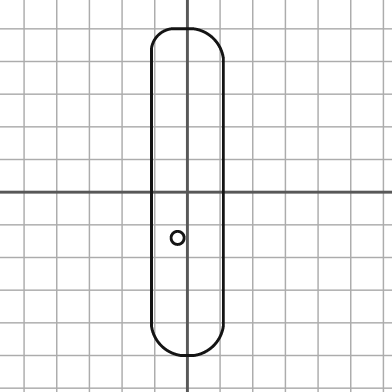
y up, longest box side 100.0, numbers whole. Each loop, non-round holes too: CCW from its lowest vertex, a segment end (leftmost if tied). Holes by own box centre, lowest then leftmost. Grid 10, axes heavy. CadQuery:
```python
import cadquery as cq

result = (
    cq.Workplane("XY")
    .moveTo(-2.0, -50.0)
    .lineTo(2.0, -50.0)
    .threePointArc((8.0, -47.0), (11.0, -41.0))
    .lineTo(11.0, 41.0)
    .threePointArc((8.0, 47.0), (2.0, 50.0))
    .lineTo(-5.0, 50.0)
    .threePointArc((-9.0, 48.0), (-11.0, 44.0))
    .lineTo(-11.0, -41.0)
    .threePointArc((-8.0, -47.0), (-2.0, -50.0))
    .close()
    .moveTo(-3.0, -14.0)
    .circle(2.0)
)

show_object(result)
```